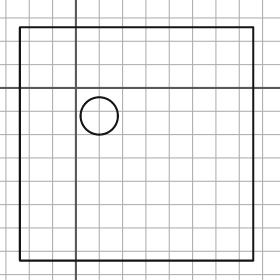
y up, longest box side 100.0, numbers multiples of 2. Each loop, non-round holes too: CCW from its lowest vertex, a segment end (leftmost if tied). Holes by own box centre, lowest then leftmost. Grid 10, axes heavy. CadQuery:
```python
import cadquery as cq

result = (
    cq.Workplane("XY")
    .moveTo(-24.0, -74.0)
    .lineTo(76.0, -74.0)
    .lineTo(76.0, 26.0)
    .lineTo(-24.0, 26.0)
    .close()
    .moveTo(10.0, -12.0)
    .circle(8.0)
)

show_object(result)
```